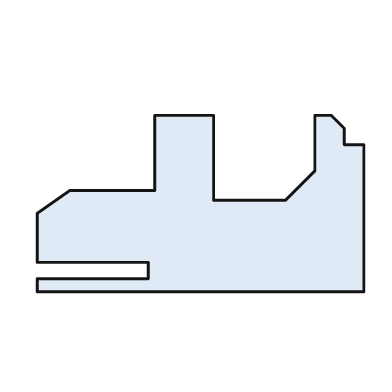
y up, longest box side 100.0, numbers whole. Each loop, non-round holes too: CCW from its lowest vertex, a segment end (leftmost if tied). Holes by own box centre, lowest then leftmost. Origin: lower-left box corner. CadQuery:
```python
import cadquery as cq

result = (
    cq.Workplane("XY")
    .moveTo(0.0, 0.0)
    .lineTo(100.0, 0.0)
    .lineTo(100.0, 45.0)
    .lineTo(94.0, 45.0)
    .lineTo(94.0, 50.0)
    .lineTo(90.0, 54.0)
    .lineTo(85.0, 54.0)
    .lineTo(85.0, 37.0)
    .lineTo(76.0, 28.0)
    .lineTo(54.0, 28.0)
    .lineTo(54.0, 54.0)
    .lineTo(36.0, 54.0)
    .lineTo(36.0, 31.0)
    .lineTo(10.0, 31.0)
    .lineTo(0.0, 24.0)
    .lineTo(0.0, 9.0)
    .lineTo(34.0, 9.0)
    .lineTo(34.0, 4.0)
    .lineTo(0.0, 4.0)
    .close()
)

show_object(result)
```